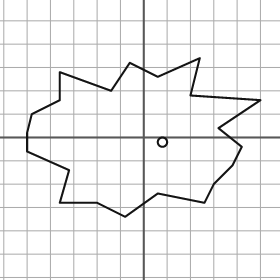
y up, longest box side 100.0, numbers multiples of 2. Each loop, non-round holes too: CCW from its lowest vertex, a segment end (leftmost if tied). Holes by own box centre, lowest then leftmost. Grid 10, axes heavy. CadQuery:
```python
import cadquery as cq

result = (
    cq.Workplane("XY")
    .moveTo(-8.0, -34.0)
    .lineTo(6.0, -24.0)
    .lineTo(26.0, -28.0)
    .lineTo(30.0, -20.0)
    .lineTo(38.0, -12.0)
    .lineTo(42.0, -4.0)
    .lineTo(32.0, 4.0)
    .lineTo(50.0, 16.0)
    .lineTo(20.0, 18.0)
    .lineTo(24.0, 34.0)
    .lineTo(6.0, 26.0)
    .lineTo(-6.0, 32.0)
    .lineTo(-14.0, 20.0)
    .lineTo(-36.0, 28.0)
    .lineTo(-36.0, 16.0)
    .lineTo(-48.0, 10.0)
    .lineTo(-50.0, 2.0)
    .lineTo(-50.0, -6.0)
    .lineTo(-32.0, -14.0)
    .lineTo(-36.0, -28.0)
    .lineTo(-20.0, -28.0)
    .close()
    .moveTo(8.0, -2.0)
    .circle(2.0)
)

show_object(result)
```